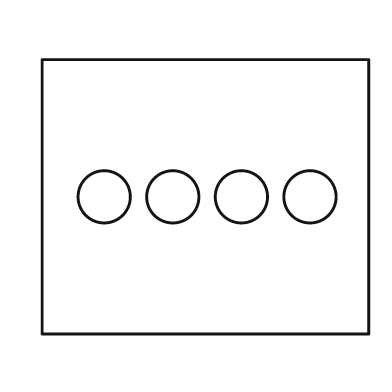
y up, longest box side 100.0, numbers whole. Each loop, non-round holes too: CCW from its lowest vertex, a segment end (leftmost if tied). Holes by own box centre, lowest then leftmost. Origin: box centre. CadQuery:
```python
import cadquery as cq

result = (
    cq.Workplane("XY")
    .moveTo(-50.0, -42.0)
    .lineTo(50.0, -42.0)
    .lineTo(50.0, 42.0)
    .lineTo(-50.0, 42.0)
    .close()
    .moveTo(-31.0, 0.0)
    .circle(8.0)
    .moveTo(-10.0, 0.0)
    .circle(8.0)
    .moveTo(11.0, 0.0)
    .circle(8.0)
    .moveTo(32.0, 0.0)
    .circle(8.0)
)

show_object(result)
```